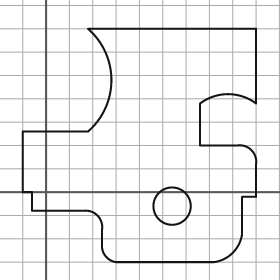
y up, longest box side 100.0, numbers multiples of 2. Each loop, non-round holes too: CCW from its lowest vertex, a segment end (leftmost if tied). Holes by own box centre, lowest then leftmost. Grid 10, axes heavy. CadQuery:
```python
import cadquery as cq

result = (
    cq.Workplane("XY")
    .moveTo(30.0, -30.0)
    .lineTo(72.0, -30.0)
    .threePointArc((80.0, -26.0), (84.0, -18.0))
    .lineTo(84.0, -2.0)
    .lineTo(90.0, -2.0)
    .lineTo(90.0, 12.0)
    .threePointArc((88.0, 18.0), (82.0, 20.0))
    .lineTo(66.0, 20.0)
    .lineTo(66.0, 38.0)
    .threePointArc((78.0, 42.0), (90.0, 38.0))
    .lineTo(90.0, 70.0)
    .lineTo(18.0, 70.0)
    .threePointArc((28.0, 48.0), (18.0, 26.0))
    .lineTo(-10.0, 26.0)
    .lineTo(-10.0, 0.0)
    .lineTo(-6.0, 0.0)
    .lineTo(-6.0, -8.0)
    .lineTo(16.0, -8.0)
    .threePointArc((22.0, -10.0), (24.0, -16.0))
    .lineTo(24.0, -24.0)
    .threePointArc((26.0, -28.0), (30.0, -30.0))
    .close()
    .moveTo(54.0, -6.0)
    .circle(8.0)
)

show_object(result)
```